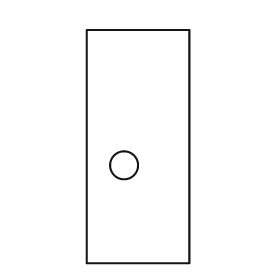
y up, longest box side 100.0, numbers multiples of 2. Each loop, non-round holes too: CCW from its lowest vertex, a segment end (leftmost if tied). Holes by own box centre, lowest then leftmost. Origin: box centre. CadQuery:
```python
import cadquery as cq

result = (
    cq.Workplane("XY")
    .moveTo(-22.0, -50.0)
    .lineTo(22.0, -50.0)
    .lineTo(22.0, 50.0)
    .lineTo(-22.0, 50.0)
    .close()
    .moveTo(-6.0, -8.0)
    .circle(6.0)
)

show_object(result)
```